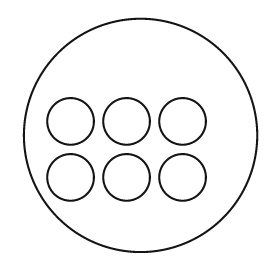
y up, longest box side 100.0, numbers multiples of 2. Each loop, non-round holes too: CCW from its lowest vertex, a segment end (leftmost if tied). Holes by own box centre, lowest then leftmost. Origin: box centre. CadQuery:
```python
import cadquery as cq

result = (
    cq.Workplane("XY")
    .moveTo(0.0, 0.0)
    .circle(50.0)
    .moveTo(-30.0, -18.0)
    .circle(10.0)
    .moveTo(-6.0, -18.0)
    .circle(10.0)
    .moveTo(18.0, -18.0)
    .circle(10.0)
    .moveTo(-30.0, 6.0)
    .circle(10.0)
    .moveTo(-6.0, 6.0)
    .circle(10.0)
    .moveTo(18.0, 6.0)
    .circle(10.0)
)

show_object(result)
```